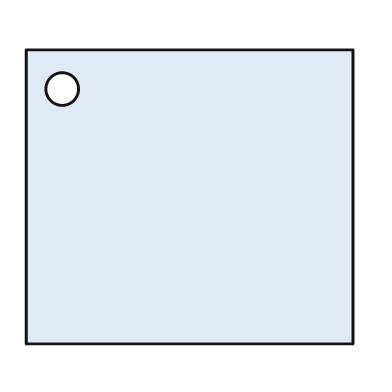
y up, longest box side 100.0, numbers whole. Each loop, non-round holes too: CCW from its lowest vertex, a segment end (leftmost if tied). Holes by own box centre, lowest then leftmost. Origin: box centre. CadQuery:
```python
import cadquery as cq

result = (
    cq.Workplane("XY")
    .moveTo(-50.0, -45.0)
    .lineTo(50.0, -45.0)
    .lineTo(50.0, 45.0)
    .lineTo(-50.0, 45.0)
    .close()
    .moveTo(-39.0, 33.0)
    .circle(5.0)
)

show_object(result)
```